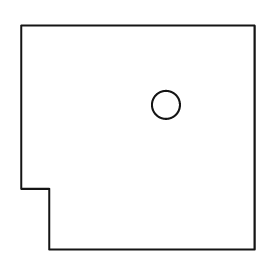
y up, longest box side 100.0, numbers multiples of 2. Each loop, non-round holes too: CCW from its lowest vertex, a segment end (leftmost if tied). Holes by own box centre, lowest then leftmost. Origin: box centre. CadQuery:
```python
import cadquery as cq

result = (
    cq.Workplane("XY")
    .moveTo(-38.0, -48.0)
    .lineTo(50.0, -48.0)
    .lineTo(50.0, 48.0)
    .lineTo(-50.0, 48.0)
    .lineTo(-50.0, -22.0)
    .lineTo(-38.0, -22.0)
    .close()
    .moveTo(12.0, 14.0)
    .circle(6.0)
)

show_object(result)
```